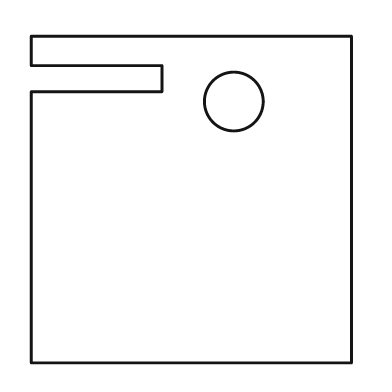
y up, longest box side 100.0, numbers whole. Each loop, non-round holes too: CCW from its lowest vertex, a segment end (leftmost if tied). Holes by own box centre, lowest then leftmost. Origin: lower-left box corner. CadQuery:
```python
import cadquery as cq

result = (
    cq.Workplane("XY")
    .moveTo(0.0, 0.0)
    .lineTo(98.0, 0.0)
    .lineTo(98.0, 100.0)
    .lineTo(0.0, 100.0)
    .lineTo(0.0, 91.0)
    .lineTo(40.0, 91.0)
    .lineTo(40.0, 83.0)
    .lineTo(0.0, 83.0)
    .close()
    .moveTo(62.0, 80.0)
    .circle(9.0)
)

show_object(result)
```